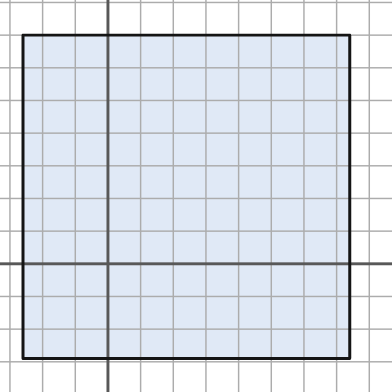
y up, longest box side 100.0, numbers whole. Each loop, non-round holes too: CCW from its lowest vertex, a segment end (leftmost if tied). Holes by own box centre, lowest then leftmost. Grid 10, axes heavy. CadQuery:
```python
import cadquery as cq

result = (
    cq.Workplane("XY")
    .moveTo(-26.0, -29.0)
    .lineTo(74.0, -29.0)
    .lineTo(74.0, 70.0)
    .lineTo(-26.0, 70.0)
    .close()
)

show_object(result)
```